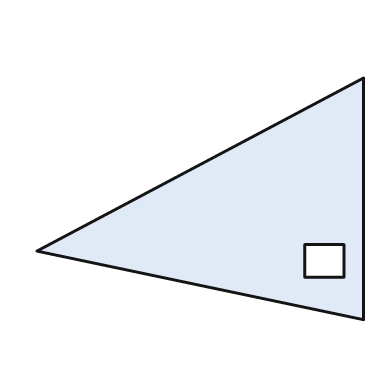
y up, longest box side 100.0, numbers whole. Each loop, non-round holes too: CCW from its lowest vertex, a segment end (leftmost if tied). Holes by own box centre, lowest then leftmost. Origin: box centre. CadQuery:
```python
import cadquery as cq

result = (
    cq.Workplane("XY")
    .moveTo(50.0, -37.0)
    .lineTo(50.0, 37.0)
    .lineTo(-50.0, -16.0)
    .close()
    .moveTo(32.0, -24.0)
    .lineTo(44.0, -24.0)
    .lineTo(44.0, -14.0)
    .lineTo(32.0, -14.0)
    .close()
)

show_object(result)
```